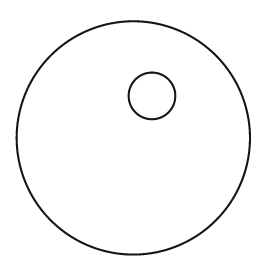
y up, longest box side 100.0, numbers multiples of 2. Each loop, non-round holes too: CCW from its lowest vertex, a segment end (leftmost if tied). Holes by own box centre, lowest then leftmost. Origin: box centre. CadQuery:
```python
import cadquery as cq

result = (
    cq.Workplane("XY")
    .moveTo(0.0, 0.0)
    .circle(50.0)
    .moveTo(8.0, 18.0)
    .circle(10.0)
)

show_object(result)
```